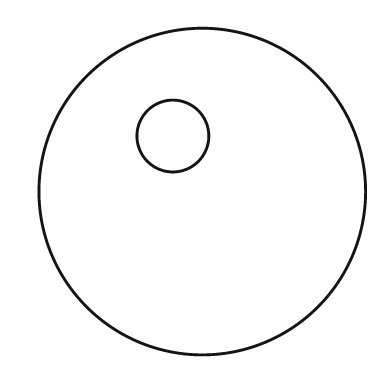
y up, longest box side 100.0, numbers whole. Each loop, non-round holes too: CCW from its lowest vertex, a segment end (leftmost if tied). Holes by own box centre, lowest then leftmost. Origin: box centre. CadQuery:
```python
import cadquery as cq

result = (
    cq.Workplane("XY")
    .moveTo(0.0, 0.0)
    .circle(50.0)
    .moveTo(-9.0, 17.0)
    .circle(11.0)
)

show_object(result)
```